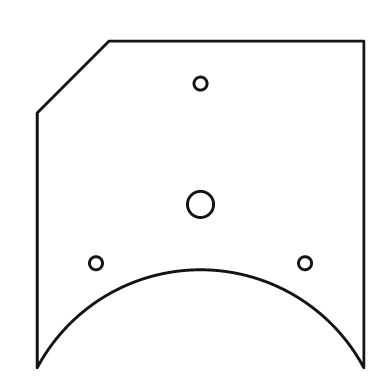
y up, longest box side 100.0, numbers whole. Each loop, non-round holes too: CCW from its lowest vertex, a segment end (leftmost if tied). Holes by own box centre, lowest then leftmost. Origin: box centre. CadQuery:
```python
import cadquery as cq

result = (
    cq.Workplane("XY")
    .moveTo(-50.0, -50.0)
    .threePointArc((0.0, -20.0), (50.0, -50.0))
    .lineTo(50.0, 50.0)
    .lineTo(-28.0, 50.0)
    .lineTo(-50.0, 28.0)
    .close()
    .moveTo(-32.0, -18.0)
    .circle(2.0)
    .moveTo(32.0, -18.0)
    .circle(2.0)
    .moveTo(0.0, 0.0)
    .circle(4.0)
    .moveTo(0.0, 37.0)
    .circle(2.0)
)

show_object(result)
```